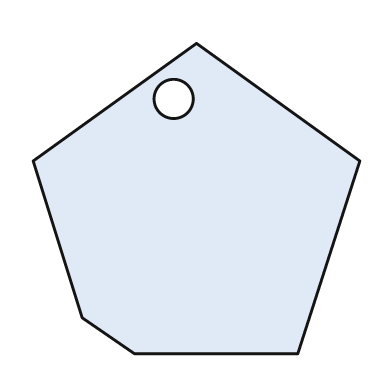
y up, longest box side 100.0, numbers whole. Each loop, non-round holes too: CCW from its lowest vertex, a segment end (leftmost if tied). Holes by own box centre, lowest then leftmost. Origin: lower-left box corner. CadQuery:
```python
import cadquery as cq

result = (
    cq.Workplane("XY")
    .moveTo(31.0, 0.0)
    .lineTo(81.0, 0.0)
    .lineTo(100.0, 59.0)
    .lineTo(50.0, 95.0)
    .lineTo(0.0, 59.0)
    .lineTo(15.0, 11.0)
    .close()
    .moveTo(43.0, 78.0)
    .circle(6.0)
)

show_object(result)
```